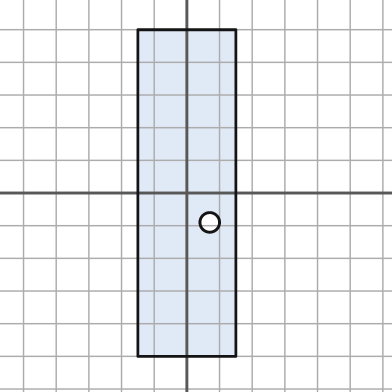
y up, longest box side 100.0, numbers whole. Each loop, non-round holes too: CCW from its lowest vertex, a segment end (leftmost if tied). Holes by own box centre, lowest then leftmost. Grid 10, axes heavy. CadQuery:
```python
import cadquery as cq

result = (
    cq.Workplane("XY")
    .moveTo(-15.0, -50.0)
    .lineTo(15.0, -50.0)
    .lineTo(15.0, 50.0)
    .lineTo(-15.0, 50.0)
    .close()
    .moveTo(7.0, -9.0)
    .circle(3.0)
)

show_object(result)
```